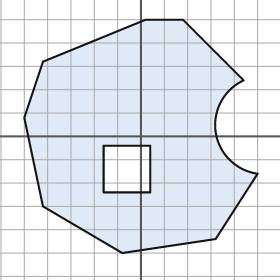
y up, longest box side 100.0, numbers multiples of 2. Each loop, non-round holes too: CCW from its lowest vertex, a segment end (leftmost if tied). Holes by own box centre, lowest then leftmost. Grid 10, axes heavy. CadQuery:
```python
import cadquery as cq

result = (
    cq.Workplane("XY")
    .moveTo(-8.0, -50.0)
    .lineTo(32.0, -44.0)
    .lineTo(50.0, -16.0)
    .threePointArc((32.0, 2.0), (44.0, 24.0))
    .lineTo(18.0, 50.0)
    .lineTo(2.0, 50.0)
    .lineTo(-42.0, 32.0)
    .lineTo(-50.0, 8.0)
    .lineTo(-42.0, -30.0)
    .close()
    .moveTo(-16.0, -24.0)
    .lineTo(4.0, -24.0)
    .lineTo(4.0, -4.0)
    .lineTo(-16.0, -4.0)
    .close()
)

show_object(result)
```